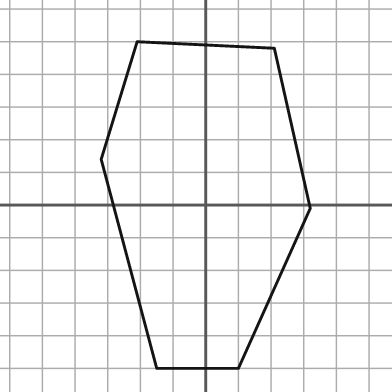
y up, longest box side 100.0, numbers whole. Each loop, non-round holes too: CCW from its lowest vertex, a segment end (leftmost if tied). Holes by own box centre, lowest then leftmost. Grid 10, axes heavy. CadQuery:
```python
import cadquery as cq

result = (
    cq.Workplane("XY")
    .moveTo(-15.0, -50.0)
    .lineTo(10.0, -50.0)
    .lineTo(32.0, -1.0)
    .lineTo(21.0, 48.0)
    .lineTo(-21.0, 50.0)
    .lineTo(-32.0, 14.0)
    .close()
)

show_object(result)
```